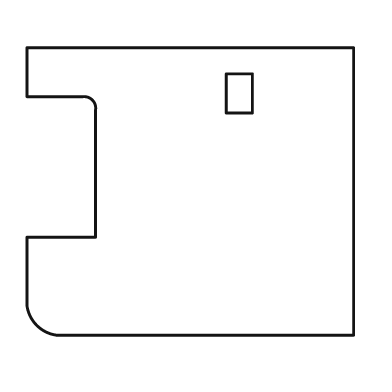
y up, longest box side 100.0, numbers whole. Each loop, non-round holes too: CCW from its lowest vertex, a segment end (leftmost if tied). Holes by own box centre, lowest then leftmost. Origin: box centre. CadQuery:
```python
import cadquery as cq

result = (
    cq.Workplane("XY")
    .moveTo(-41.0, -44.0)
    .lineTo(50.0, -44.0)
    .lineTo(50.0, 44.0)
    .lineTo(-50.0, 44.0)
    .lineTo(-50.0, 29.0)
    .lineTo(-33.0, 29.0)
    .threePointArc((-30.0, 28.0), (-29.0, 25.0))
    .lineTo(-29.0, -14.0)
    .lineTo(-50.0, -14.0)
    .lineTo(-50.0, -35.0)
    .threePointArc((-47.0, -41.0), (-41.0, -44.0))
    .close()
    .moveTo(11.0, 24.0)
    .lineTo(19.0, 24.0)
    .lineTo(19.0, 36.0)
    .lineTo(11.0, 36.0)
    .close()
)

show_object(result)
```